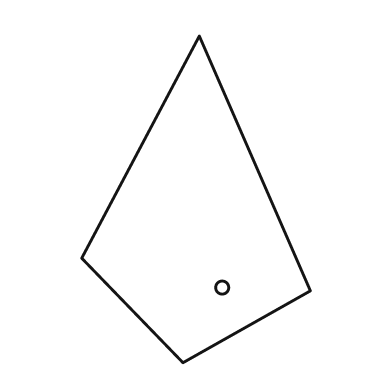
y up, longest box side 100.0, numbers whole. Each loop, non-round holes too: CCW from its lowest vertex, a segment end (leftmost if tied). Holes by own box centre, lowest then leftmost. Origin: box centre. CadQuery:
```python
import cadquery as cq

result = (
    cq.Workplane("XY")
    .moveTo(-4.0, -50.0)
    .lineTo(35.0, -28.0)
    .lineTo(1.0, 50.0)
    .lineTo(-35.0, -18.0)
    .close()
    .moveTo(8.0, -27.0)
    .circle(2.0)
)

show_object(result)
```